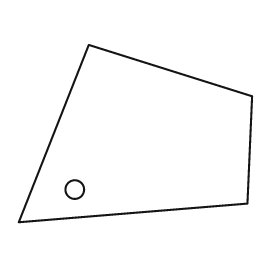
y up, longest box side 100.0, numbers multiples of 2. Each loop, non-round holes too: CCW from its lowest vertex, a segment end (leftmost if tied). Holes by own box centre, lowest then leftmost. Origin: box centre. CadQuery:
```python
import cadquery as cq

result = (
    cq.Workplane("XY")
    .moveTo(-50.0, -38.0)
    .lineTo(48.0, -30.0)
    .lineTo(50.0, 16.0)
    .lineTo(-20.0, 38.0)
    .close()
    .moveTo(-26.0, -24.0)
    .circle(4.0)
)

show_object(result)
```